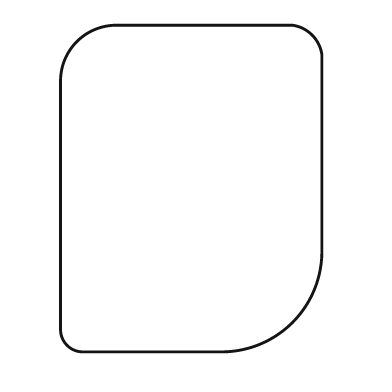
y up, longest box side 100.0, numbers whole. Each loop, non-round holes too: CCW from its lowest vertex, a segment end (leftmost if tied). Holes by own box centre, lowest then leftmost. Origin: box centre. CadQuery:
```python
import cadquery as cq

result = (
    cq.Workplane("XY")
    .moveTo(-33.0, -50.0)
    .lineTo(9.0, -50.0)
    .threePointArc((31.0, -41.0), (40.0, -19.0))
    .lineTo(40.0, 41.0)
    .threePointArc((37.0, 47.0), (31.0, 50.0))
    .lineTo(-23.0, 50.0)
    .threePointArc((-35.0, 45.0), (-40.0, 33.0))
    .lineTo(-40.0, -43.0)
    .threePointArc((-38.0, -48.0), (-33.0, -50.0))
    .close()
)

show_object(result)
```